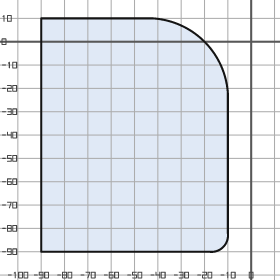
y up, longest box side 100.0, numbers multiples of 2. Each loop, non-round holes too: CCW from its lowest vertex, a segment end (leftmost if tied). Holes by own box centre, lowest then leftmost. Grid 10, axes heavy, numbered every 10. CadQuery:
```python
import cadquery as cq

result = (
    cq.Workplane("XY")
    .moveTo(-90.0, -90.0)
    .lineTo(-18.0, -90.0)
    .threePointArc((-12.0, -88.0), (-10.0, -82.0))
    .lineTo(-10.0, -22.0)
    .threePointArc((-20.0, 0.0), (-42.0, 10.0))
    .lineTo(-90.0, 10.0)
    .close()
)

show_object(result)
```